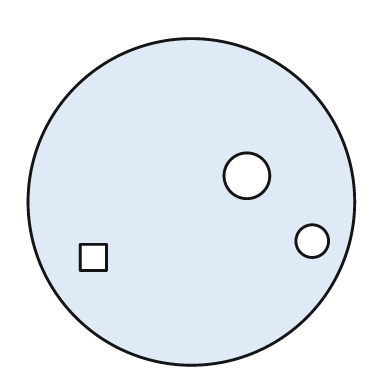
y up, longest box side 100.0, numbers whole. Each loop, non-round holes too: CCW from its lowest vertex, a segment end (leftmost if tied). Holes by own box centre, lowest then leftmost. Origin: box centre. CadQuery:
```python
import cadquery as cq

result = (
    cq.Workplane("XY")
    .moveTo(0.0, 0.0)
    .circle(50.0)
    .moveTo(-34.0, -21.0)
    .lineTo(-26.0, -21.0)
    .lineTo(-26.0, -13.0)
    .lineTo(-34.0, -13.0)
    .close()
    .moveTo(37.0, -12.0)
    .circle(5.0)
    .moveTo(17.0, 8.0)
    .circle(7.0)
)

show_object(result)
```